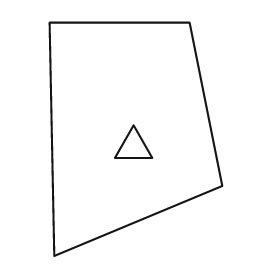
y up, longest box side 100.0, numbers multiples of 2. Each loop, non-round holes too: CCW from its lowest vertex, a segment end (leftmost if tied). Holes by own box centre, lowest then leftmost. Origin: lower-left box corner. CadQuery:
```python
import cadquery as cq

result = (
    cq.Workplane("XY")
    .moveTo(2.0, 0.0)
    .lineTo(74.0, 30.0)
    .lineTo(60.0, 100.0)
    .lineTo(0.0, 100.0)
    .close()
    .moveTo(28.0, 42.0)
    .lineTo(44.0, 42.0)
    .lineTo(36.0, 56.0)
    .close()
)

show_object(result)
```